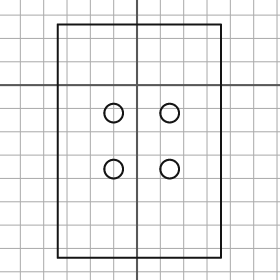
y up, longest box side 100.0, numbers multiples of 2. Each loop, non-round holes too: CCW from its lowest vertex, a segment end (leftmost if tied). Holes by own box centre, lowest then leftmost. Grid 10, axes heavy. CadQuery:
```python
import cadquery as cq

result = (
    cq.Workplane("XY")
    .moveTo(-34.0, -74.0)
    .lineTo(36.0, -74.0)
    .lineTo(36.0, 26.0)
    .lineTo(-34.0, 26.0)
    .close()
    .moveTo(-10.0, -36.0)
    .circle(4.0)
    .moveTo(14.0, -36.0)
    .circle(4.0)
    .moveTo(-10.0, -12.0)
    .circle(4.0)
    .moveTo(14.0, -12.0)
    .circle(4.0)
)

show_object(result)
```